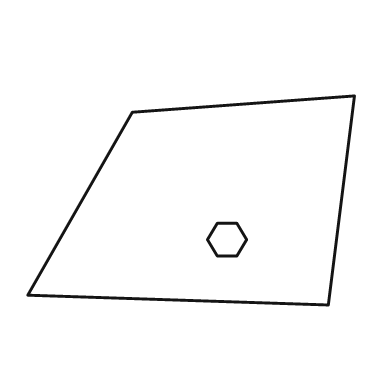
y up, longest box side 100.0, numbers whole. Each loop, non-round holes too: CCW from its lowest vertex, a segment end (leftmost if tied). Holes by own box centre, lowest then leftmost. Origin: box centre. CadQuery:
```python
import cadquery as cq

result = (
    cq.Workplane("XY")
    .moveTo(42.0, -32.0)
    .lineTo(50.0, 32.0)
    .lineTo(-18.0, 27.0)
    .lineTo(-50.0, -29.0)
    .close()
    .moveTo(8.0, -17.0)
    .lineTo(14.0, -17.0)
    .lineTo(17.0, -12.0)
    .lineTo(14.0, -7.0)
    .lineTo(8.0, -7.0)
    .lineTo(5.0, -12.0)
    .close()
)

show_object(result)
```